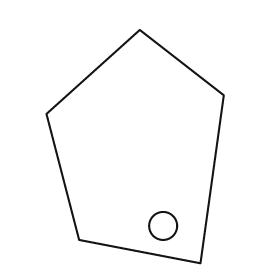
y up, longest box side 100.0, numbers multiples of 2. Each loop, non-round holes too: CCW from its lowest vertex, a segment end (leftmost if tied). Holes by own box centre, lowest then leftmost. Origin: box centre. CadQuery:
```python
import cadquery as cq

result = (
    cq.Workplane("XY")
    .moveTo(28.0, -50.0)
    .lineTo(38.0, 22.0)
    .lineTo(2.0, 50.0)
    .lineTo(-38.0, 14.0)
    .lineTo(-24.0, -40.0)
    .close()
    .moveTo(12.0, -34.0)
    .circle(6.0)
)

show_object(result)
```